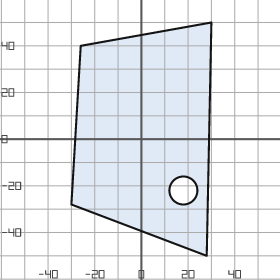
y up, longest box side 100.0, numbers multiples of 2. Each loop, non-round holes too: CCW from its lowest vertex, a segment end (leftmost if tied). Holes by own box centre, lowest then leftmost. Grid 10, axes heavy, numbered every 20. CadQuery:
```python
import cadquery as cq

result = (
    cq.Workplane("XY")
    .moveTo(28.0, -50.0)
    .lineTo(30.0, 50.0)
    .lineTo(-26.0, 40.0)
    .lineTo(-30.0, -28.0)
    .close()
    .moveTo(18.0, -22.0)
    .circle(6.0)
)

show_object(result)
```